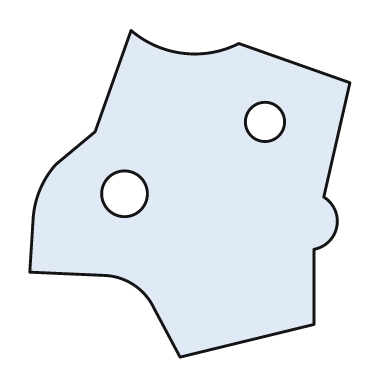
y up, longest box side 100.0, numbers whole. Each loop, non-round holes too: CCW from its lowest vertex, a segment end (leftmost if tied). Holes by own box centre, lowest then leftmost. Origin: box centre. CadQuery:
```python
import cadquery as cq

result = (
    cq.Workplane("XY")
    .moveTo(-3.0, -50.0)
    .lineTo(38.0, -40.0)
    .lineTo(38.0, -17.0)
    .threePointArc((45.0, -10.0), (41.0, -1.0))
    .lineTo(49.0, 34.0)
    .lineTo(15.0, 46.0)
    .threePointArc((-2.0, 43.0), (-18.0, 50.0))
    .lineTo(-29.0, 19.0)
    .lineTo(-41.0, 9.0)
    .threePointArc((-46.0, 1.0), (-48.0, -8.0))
    .lineTo(-49.0, -24.0)
    .lineTo(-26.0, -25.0)
    .threePointArc((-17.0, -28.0), (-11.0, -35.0))
    .close()
    .moveTo(-20.0, 0.0)
    .circle(7.0)
    .moveTo(23.0, 22.0)
    .circle(6.0)
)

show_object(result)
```